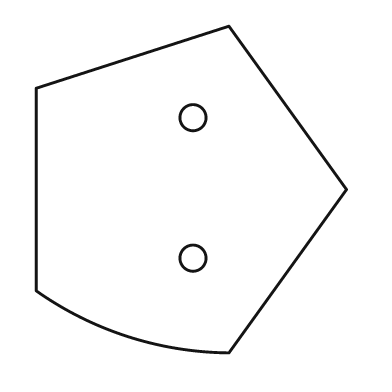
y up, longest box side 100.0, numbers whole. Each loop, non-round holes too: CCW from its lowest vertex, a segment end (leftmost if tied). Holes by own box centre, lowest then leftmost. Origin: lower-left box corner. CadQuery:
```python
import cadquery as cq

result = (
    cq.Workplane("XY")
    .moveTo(59.0, 0.0)
    .lineTo(95.0, 50.0)
    .lineTo(59.0, 100.0)
    .lineTo(0.0, 81.0)
    .lineTo(0.0, 19.0)
    .threePointArc((28.0, 5.0), (59.0, 0.0))
    .close()
    .moveTo(48.0, 29.0)
    .circle(4.0)
    .moveTo(48.0, 72.0)
    .circle(4.0)
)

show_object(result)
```